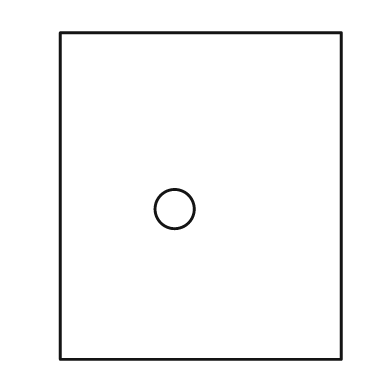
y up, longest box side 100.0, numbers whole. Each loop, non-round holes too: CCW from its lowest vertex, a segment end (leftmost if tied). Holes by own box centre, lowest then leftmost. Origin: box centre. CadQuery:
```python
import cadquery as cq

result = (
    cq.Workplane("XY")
    .moveTo(-43.0, -50.0)
    .lineTo(43.0, -50.0)
    .lineTo(43.0, 50.0)
    .lineTo(-43.0, 50.0)
    .close()
    .moveTo(-8.0, -4.0)
    .circle(6.0)
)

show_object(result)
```